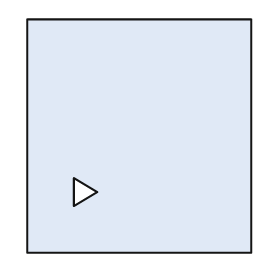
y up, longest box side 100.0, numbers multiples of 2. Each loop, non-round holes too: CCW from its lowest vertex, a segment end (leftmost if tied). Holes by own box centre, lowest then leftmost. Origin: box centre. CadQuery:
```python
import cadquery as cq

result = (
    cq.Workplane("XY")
    .moveTo(-48.0, -50.0)
    .lineTo(48.0, -50.0)
    .lineTo(48.0, 50.0)
    .lineTo(-48.0, 50.0)
    .close()
    .moveTo(-28.0, -30.0)
    .lineTo(-18.0, -24.0)
    .lineTo(-28.0, -18.0)
    .close()
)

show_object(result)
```